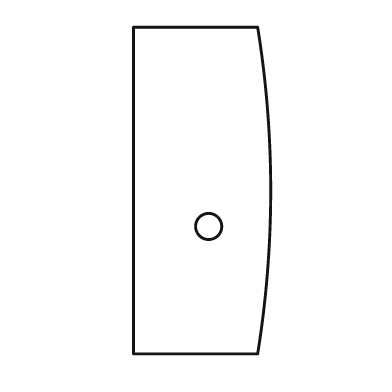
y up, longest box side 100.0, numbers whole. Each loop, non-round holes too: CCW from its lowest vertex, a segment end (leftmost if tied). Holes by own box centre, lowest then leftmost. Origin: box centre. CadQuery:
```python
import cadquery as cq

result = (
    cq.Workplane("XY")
    .moveTo(-21.0, -50.0)
    .lineTo(17.0, -50.0)
    .threePointArc((21.0, 0.0), (17.0, 50.0))
    .lineTo(-21.0, 50.0)
    .close()
    .moveTo(2.0, -11.0)
    .circle(4.0)
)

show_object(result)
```